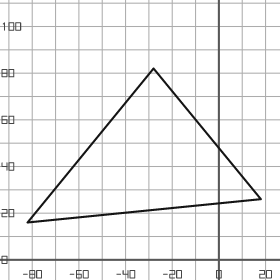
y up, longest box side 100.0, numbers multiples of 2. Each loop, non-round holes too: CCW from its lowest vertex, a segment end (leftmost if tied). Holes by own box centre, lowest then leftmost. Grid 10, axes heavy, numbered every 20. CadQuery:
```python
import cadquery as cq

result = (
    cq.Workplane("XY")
    .moveTo(-82.0, 16.0)
    .lineTo(18.0, 26.0)
    .lineTo(-28.0, 82.0)
    .close()
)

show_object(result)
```